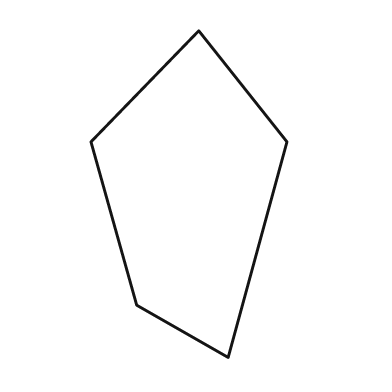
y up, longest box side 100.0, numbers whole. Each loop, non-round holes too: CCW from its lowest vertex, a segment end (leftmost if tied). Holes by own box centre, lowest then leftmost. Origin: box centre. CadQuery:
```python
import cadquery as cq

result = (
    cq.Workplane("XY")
    .moveTo(12.0, -50.0)
    .lineTo(30.0, 16.0)
    .lineTo(3.0, 50.0)
    .lineTo(-30.0, 16.0)
    .lineTo(-16.0, -34.0)
    .close()
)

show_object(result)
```